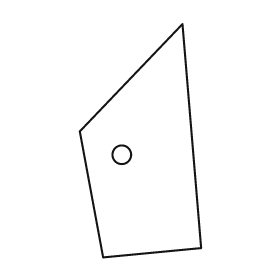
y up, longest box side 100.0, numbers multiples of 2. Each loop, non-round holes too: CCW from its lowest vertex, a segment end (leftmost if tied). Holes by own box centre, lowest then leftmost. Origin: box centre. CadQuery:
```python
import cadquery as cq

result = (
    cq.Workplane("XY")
    .moveTo(-16.0, -50.0)
    .lineTo(26.0, -46.0)
    .lineTo(18.0, 50.0)
    .lineTo(-26.0, 4.0)
    .close()
    .moveTo(-8.0, -6.0)
    .circle(4.0)
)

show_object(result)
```